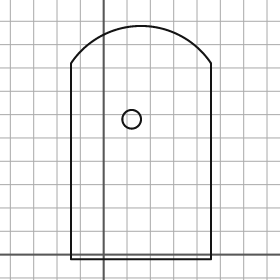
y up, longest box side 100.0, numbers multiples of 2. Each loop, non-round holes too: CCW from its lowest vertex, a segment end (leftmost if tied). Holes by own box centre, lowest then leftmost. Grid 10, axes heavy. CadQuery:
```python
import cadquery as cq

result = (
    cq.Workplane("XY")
    .moveTo(-14.0, -2.0)
    .lineTo(46.0, -2.0)
    .lineTo(46.0, 82.0)
    .threePointArc((16.0, 98.0), (-14.0, 82.0))
    .close()
    .moveTo(12.0, 58.0)
    .circle(4.0)
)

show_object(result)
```